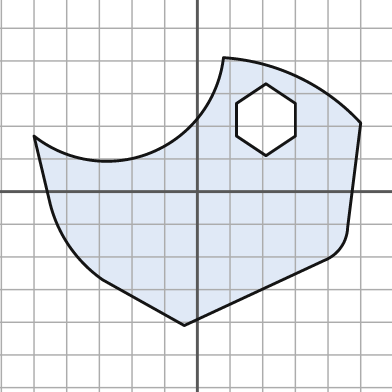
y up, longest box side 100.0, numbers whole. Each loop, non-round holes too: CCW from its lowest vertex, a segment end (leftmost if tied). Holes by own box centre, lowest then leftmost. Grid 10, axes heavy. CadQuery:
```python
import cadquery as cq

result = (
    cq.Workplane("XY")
    .moveTo(-4.0, -41.0)
    .lineTo(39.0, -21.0)
    .threePointArc((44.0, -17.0), (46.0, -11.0))
    .lineTo(50.0, 21.0)
    .threePointArc((31.0, 35.0), (8.0, 41.0))
    .threePointArc((-14.0, 12.0), (-50.0, 17.0))
    .lineTo(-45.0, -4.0)
    .threePointArc((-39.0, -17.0), (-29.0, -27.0))
    .close()
    .moveTo(21.0, 11.0)
    .lineTo(30.0, 17.0)
    .lineTo(30.0, 27.0)
    .lineTo(21.0, 33.0)
    .lineTo(12.0, 27.0)
    .lineTo(12.0, 17.0)
    .close()
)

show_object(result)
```